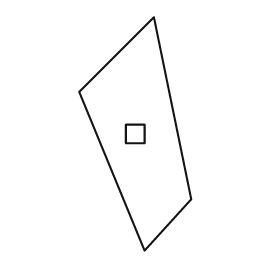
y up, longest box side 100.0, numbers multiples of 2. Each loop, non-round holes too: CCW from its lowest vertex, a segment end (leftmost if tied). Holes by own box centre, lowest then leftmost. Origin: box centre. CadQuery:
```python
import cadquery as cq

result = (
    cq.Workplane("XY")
    .moveTo(4.0, -50.0)
    .lineTo(24.0, -28.0)
    .lineTo(8.0, 50.0)
    .lineTo(-24.0, 18.0)
    .close()
    .moveTo(-4.0, -4.0)
    .lineTo(4.0, -4.0)
    .lineTo(4.0, 4.0)
    .lineTo(-4.0, 4.0)
    .close()
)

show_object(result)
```